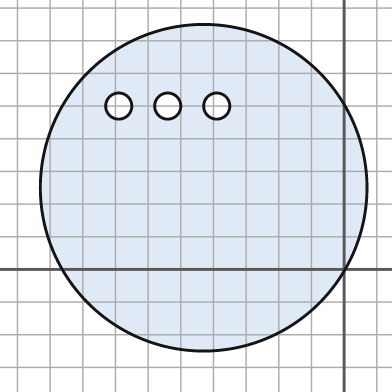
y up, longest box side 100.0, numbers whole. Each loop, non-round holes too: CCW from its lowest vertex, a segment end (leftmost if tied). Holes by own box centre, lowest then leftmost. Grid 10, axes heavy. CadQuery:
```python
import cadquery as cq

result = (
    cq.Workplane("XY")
    .moveTo(-43.0, 25.0)
    .circle(50.0)
    .moveTo(-69.0, 50.0)
    .circle(4.0)
    .moveTo(-54.0, 50.0)
    .circle(4.0)
    .moveTo(-39.0, 50.0)
    .circle(4.0)
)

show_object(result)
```